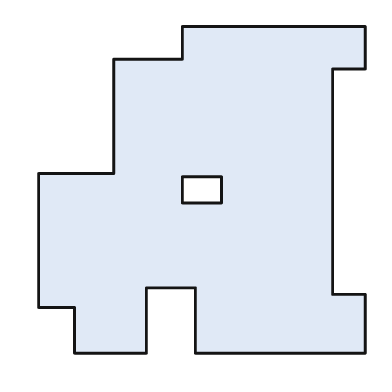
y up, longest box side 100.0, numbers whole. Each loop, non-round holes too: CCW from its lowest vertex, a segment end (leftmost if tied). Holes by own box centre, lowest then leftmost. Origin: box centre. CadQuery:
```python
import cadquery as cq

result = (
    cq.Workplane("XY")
    .moveTo(-39.0, -50.0)
    .lineTo(-17.0, -50.0)
    .lineTo(-17.0, -30.0)
    .lineTo(-2.0, -30.0)
    .lineTo(-2.0, -50.0)
    .lineTo(50.0, -50.0)
    .lineTo(50.0, -32.0)
    .lineTo(40.0, -32.0)
    .lineTo(40.0, 37.0)
    .lineTo(50.0, 37.0)
    .lineTo(50.0, 50.0)
    .lineTo(-6.0, 50.0)
    .lineTo(-6.0, 40.0)
    .lineTo(-27.0, 40.0)
    .lineTo(-27.0, 5.0)
    .lineTo(-50.0, 5.0)
    .lineTo(-50.0, -36.0)
    .lineTo(-39.0, -36.0)
    .close()
    .moveTo(-6.0, -4.0)
    .lineTo(6.0, -4.0)
    .lineTo(6.0, 4.0)
    .lineTo(-6.0, 4.0)
    .close()
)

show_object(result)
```